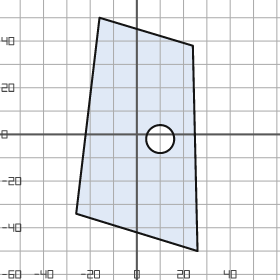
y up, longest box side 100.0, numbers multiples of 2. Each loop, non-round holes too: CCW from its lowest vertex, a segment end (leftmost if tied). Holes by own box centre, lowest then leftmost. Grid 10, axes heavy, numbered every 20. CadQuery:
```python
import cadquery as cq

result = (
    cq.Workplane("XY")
    .moveTo(26.0, -50.0)
    .lineTo(24.0, 38.0)
    .lineTo(-16.0, 50.0)
    .lineTo(-26.0, -34.0)
    .close()
    .moveTo(10.0, -2.0)
    .circle(6.0)
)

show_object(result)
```